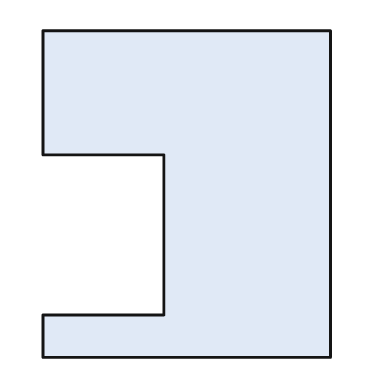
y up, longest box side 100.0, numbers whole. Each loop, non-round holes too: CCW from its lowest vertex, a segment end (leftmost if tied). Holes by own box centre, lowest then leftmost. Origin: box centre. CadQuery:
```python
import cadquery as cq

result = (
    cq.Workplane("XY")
    .moveTo(-44.0, -50.0)
    .lineTo(44.0, -50.0)
    .lineTo(44.0, 50.0)
    .lineTo(-44.0, 50.0)
    .lineTo(-44.0, 12.0)
    .lineTo(-7.0, 12.0)
    .lineTo(-7.0, -37.0)
    .lineTo(-44.0, -37.0)
    .close()
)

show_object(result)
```